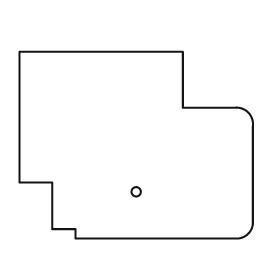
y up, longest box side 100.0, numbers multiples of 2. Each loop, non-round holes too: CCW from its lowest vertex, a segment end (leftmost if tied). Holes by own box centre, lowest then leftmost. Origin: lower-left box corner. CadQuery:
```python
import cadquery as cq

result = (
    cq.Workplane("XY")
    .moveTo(24.0, 0.0)
    .lineTo(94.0, 0.0)
    .threePointArc((98.0, 2.0), (100.0, 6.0))
    .lineTo(100.0, 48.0)
    .threePointArc((98.0, 54.0), (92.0, 56.0))
    .lineTo(70.0, 56.0)
    .lineTo(70.0, 80.0)
    .lineTo(0.0, 80.0)
    .lineTo(0.0, 24.0)
    .lineTo(14.0, 24.0)
    .lineTo(14.0, 4.0)
    .lineTo(24.0, 4.0)
    .close()
    .moveTo(50.0, 20.0)
    .circle(2.0)
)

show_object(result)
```